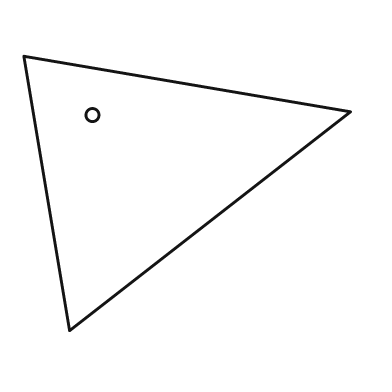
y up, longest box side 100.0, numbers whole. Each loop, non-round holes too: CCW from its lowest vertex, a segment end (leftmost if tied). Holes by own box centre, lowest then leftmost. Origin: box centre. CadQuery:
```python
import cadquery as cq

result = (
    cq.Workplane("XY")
    .moveTo(-36.0, -42.0)
    .lineTo(50.0, 25.0)
    .lineTo(-50.0, 42.0)
    .close()
    .moveTo(-29.0, 24.0)
    .circle(2.0)
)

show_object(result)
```